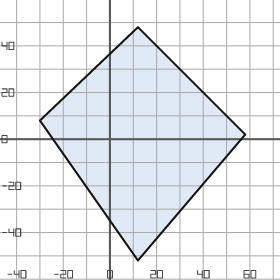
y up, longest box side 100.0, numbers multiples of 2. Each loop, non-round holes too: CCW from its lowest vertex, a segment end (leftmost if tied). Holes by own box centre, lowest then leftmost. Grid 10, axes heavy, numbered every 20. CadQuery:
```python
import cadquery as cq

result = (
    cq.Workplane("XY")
    .moveTo(12.0, -52.0)
    .lineTo(58.0, 2.0)
    .lineTo(12.0, 48.0)
    .lineTo(-30.0, 8.0)
    .close()
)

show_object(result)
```